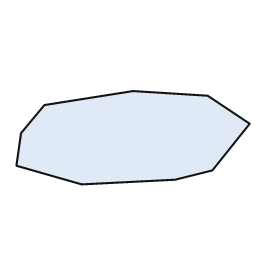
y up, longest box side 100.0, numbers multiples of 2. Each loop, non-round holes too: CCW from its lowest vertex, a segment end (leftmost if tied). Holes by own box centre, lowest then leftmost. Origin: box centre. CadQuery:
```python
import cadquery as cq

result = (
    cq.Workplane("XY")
    .moveTo(-22.0, -20.0)
    .lineTo(18.0, -18.0)
    .lineTo(34.0, -14.0)
    .lineTo(50.0, 6.0)
    .lineTo(32.0, 18.0)
    .lineTo(0.0, 20.0)
    .lineTo(-38.0, 14.0)
    .lineTo(-48.0, 2.0)
    .lineTo(-50.0, -12.0)
    .close()
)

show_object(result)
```